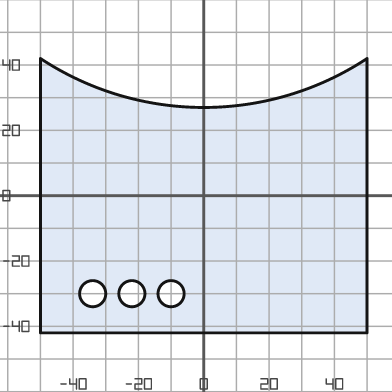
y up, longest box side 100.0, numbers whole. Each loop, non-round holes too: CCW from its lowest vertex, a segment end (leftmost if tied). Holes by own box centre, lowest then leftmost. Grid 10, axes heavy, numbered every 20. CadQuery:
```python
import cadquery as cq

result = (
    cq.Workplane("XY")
    .moveTo(-50.0, -42.0)
    .lineTo(50.0, -42.0)
    .lineTo(50.0, 42.0)
    .threePointArc((0.0, 27.0), (-50.0, 42.0))
    .close()
    .moveTo(-34.0, -30.0)
    .circle(4.0)
    .moveTo(-22.0, -30.0)
    .circle(4.0)
    .moveTo(-10.0, -30.0)
    .circle(4.0)
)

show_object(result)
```